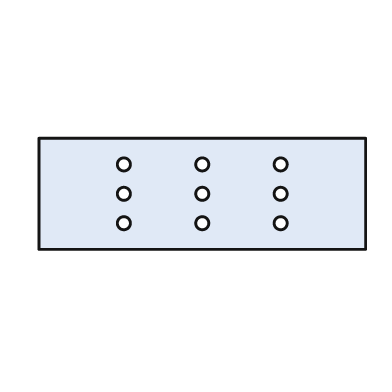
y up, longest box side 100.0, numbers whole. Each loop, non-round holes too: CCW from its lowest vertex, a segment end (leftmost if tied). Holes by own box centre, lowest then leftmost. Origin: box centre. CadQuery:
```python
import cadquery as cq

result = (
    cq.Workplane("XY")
    .moveTo(-50.0, -17.0)
    .lineTo(50.0, -17.0)
    .lineTo(50.0, 17.0)
    .lineTo(-50.0, 17.0)
    .close()
    .moveTo(-24.0, -9.0)
    .circle(2.0)
    .moveTo(0.0, -9.0)
    .circle(2.0)
    .moveTo(24.0, -9.0)
    .circle(2.0)
    .moveTo(-24.0, 0.0)
    .circle(2.0)
    .moveTo(0.0, 0.0)
    .circle(2.0)
    .moveTo(24.0, 0.0)
    .circle(2.0)
    .moveTo(-24.0, 9.0)
    .circle(2.0)
    .moveTo(0.0, 9.0)
    .circle(2.0)
    .moveTo(24.0, 9.0)
    .circle(2.0)
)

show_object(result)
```